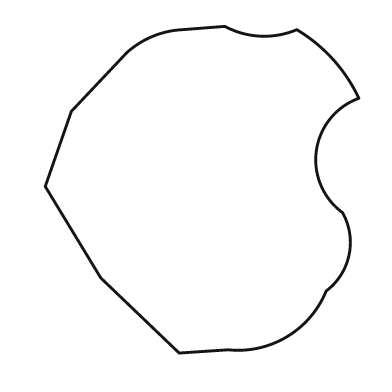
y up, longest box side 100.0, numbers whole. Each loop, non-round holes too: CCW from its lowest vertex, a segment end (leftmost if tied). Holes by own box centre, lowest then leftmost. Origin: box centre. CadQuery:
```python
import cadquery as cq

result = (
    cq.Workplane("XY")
    .moveTo(-7.0, -50.0)
    .lineTo(8.0, -49.0)
    .threePointArc((26.0, -45.0), (38.0, -31.0))
    .threePointArc((45.0, -20.0), (43.0, -7.0))
    .threePointArc((35.0, 12.0), (48.0, 28.0))
    .threePointArc((40.0, 40.0), (29.0, 49.0))
    .threePointArc((18.0, 47.0), (7.0, 50.0))
    .lineTo(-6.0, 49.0)
    .threePointArc((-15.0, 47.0), (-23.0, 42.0))
    .lineTo(-40.0, 24.0)
    .lineTo(-48.0, 1.0)
    .lineTo(-31.0, -27.0)
    .close()
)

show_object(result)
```